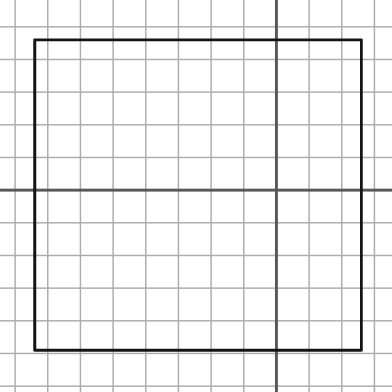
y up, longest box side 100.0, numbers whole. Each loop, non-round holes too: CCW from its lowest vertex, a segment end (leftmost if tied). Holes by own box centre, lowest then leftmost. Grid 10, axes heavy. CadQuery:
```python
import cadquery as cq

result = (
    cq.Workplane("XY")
    .moveTo(-74.0, -49.0)
    .lineTo(26.0, -49.0)
    .lineTo(26.0, 46.0)
    .lineTo(-74.0, 46.0)
    .close()
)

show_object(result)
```